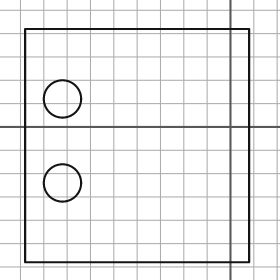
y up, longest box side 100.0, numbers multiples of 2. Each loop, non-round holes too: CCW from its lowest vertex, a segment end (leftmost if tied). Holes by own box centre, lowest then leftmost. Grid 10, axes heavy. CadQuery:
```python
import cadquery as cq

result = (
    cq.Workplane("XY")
    .moveTo(-88.0, -58.0)
    .lineTo(8.0, -58.0)
    .lineTo(8.0, 42.0)
    .lineTo(-88.0, 42.0)
    .close()
    .moveTo(-72.0, -24.0)
    .circle(8.0)
    .moveTo(-72.0, 12.0)
    .circle(8.0)
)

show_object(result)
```